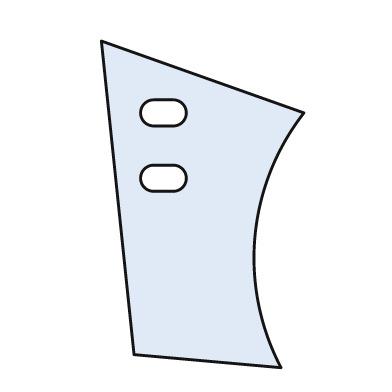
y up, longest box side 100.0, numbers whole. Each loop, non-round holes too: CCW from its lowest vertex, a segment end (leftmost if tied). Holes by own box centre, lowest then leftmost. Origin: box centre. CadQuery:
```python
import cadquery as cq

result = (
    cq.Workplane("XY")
    .moveTo(24.0, -50.0)
    .threePointArc((16.0, -10.0), (31.0, 28.0))
    .lineTo(-31.0, 50.0)
    .lineTo(-21.0, -46.0)
    .close()
    .moveTo(-15.0, 4.0)
    .lineTo(-9.0, 4.0)
    .threePointArc((-5.0, 8.0), (-9.0, 12.0))
    .lineTo(-15.0, 12.0)
    .threePointArc((-19.0, 8.0), (-15.0, 4.0))
    .close()
    .moveTo(-15.0, 24.0)
    .lineTo(-9.0, 24.0)
    .threePointArc((-5.0, 28.0), (-9.0, 32.0))
    .lineTo(-15.0, 32.0)
    .threePointArc((-19.0, 28.0), (-15.0, 24.0))
    .close()
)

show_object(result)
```